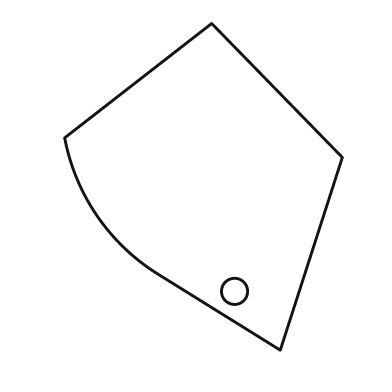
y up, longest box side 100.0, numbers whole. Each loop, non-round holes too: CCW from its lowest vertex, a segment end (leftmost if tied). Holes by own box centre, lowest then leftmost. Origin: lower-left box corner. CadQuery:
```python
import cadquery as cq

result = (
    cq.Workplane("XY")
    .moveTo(66.0, 0.0)
    .lineTo(85.0, 59.0)
    .lineTo(45.0, 100.0)
    .lineTo(0.0, 65.0)
    .threePointArc((10.0, 41.0), (29.0, 23.0))
    .close()
    .moveTo(52.0, 18.0)
    .circle(4.0)
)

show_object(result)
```